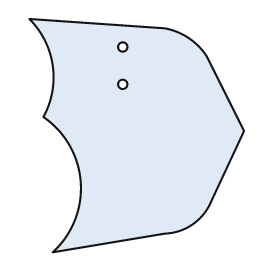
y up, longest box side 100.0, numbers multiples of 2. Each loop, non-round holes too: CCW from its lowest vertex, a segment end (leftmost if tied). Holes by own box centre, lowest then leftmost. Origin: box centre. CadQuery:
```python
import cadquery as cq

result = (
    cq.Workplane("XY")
    .moveTo(-36.0, -50.0)
    .lineTo(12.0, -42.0)
    .threePointArc((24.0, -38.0), (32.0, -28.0))
    .lineTo(46.0, 2.0)
    .lineTo(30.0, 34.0)
    .threePointArc((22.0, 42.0), (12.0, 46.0))
    .lineTo(-46.0, 50.0)
    .threePointArc((-36.0, 30.0), (-40.0, 8.0))
    .threePointArc((-24.0, -20.0), (-36.0, -50.0))
    .close()
    .moveTo(-6.0, 22.0)
    .circle(2.0)
    .moveTo(-6.0, 38.0)
    .circle(2.0)
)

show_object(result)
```